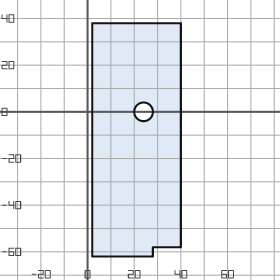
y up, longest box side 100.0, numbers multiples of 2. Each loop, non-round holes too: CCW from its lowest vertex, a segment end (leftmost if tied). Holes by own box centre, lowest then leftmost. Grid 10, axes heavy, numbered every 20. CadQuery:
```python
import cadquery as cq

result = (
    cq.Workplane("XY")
    .moveTo(2.0, -62.0)
    .lineTo(28.0, -62.0)
    .lineTo(28.0, -58.0)
    .lineTo(40.0, -58.0)
    .lineTo(40.0, 38.0)
    .lineTo(2.0, 38.0)
    .close()
    .moveTo(24.0, 0.0)
    .circle(4.0)
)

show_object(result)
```